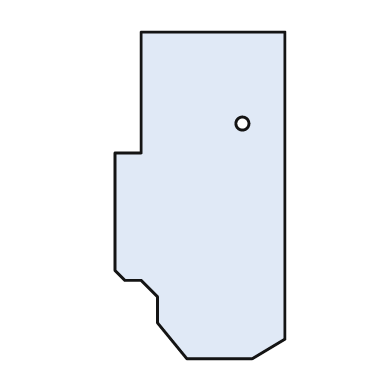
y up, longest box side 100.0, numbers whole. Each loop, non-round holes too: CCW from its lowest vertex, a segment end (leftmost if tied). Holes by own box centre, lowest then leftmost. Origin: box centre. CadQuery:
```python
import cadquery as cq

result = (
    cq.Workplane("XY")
    .moveTo(-4.0, -50.0)
    .lineTo(16.0, -50.0)
    .lineTo(26.0, -44.0)
    .lineTo(26.0, 50.0)
    .lineTo(-18.0, 50.0)
    .lineTo(-18.0, 13.0)
    .lineTo(-26.0, 13.0)
    .lineTo(-26.0, -23.0)
    .lineTo(-23.0, -26.0)
    .lineTo(-18.0, -26.0)
    .lineTo(-13.0, -31.0)
    .lineTo(-13.0, -39.0)
    .close()
    .moveTo(13.0, 22.0)
    .circle(2.0)
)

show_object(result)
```